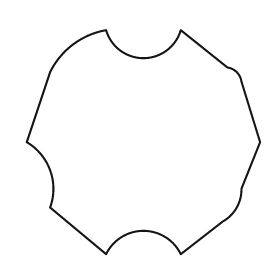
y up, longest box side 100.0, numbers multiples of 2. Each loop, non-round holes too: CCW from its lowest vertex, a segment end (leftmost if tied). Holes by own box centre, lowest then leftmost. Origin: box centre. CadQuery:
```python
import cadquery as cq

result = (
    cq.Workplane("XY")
    .moveTo(-16.0, -48.0)
    .threePointArc((0.0, -38.0), (16.0, -48.0))
    .lineTo(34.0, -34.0)
    .threePointArc((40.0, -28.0), (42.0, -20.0))
    .lineTo(50.0, 0.0)
    .lineTo(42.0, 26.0)
    .threePointArc((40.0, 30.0), (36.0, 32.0))
    .lineTo(16.0, 48.0)
    .threePointArc((0.0, 36.0), (-16.0, 48.0))
    .threePointArc((-30.0, 42.0), (-40.0, 30.0))
    .lineTo(-50.0, 0.0)
    .threePointArc((-40.0, -12.0), (-40.0, -28.0))
    .close()
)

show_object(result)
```